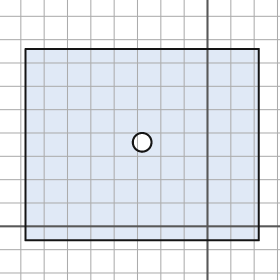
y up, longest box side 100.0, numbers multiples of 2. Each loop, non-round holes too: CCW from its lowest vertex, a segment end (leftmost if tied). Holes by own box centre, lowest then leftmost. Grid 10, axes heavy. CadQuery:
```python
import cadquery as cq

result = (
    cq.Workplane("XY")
    .moveTo(-78.0, -6.0)
    .lineTo(22.0, -6.0)
    .lineTo(22.0, 76.0)
    .lineTo(-78.0, 76.0)
    .close()
    .moveTo(-28.0, 36.0)
    .circle(4.0)
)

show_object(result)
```